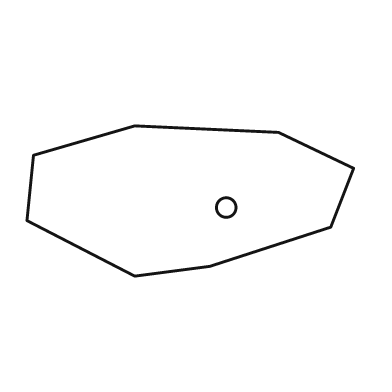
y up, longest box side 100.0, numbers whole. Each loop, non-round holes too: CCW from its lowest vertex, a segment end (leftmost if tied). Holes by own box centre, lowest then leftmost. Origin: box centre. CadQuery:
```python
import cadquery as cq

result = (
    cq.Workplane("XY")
    .moveTo(-17.0, -23.0)
    .lineTo(6.0, -20.0)
    .lineTo(43.0, -8.0)
    .lineTo(50.0, 10.0)
    .lineTo(27.0, 21.0)
    .lineTo(-17.0, 23.0)
    .lineTo(-48.0, 14.0)
    .lineTo(-50.0, -6.0)
    .close()
    .moveTo(11.0, -2.0)
    .circle(3.0)
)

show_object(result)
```